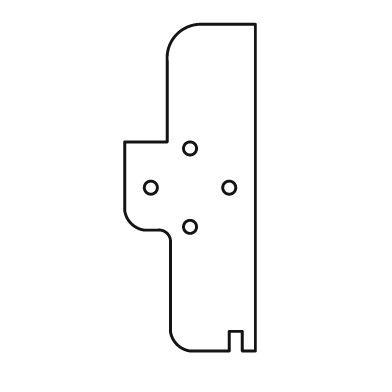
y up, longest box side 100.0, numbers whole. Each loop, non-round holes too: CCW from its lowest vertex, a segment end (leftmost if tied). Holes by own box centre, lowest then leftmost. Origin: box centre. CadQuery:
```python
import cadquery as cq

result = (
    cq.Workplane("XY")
    .moveTo(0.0, -50.0)
    .lineTo(12.0, -50.0)
    .lineTo(12.0, -44.0)
    .lineTo(16.0, -44.0)
    .lineTo(16.0, -50.0)
    .lineTo(20.0, -50.0)
    .lineTo(20.0, 50.0)
    .lineTo(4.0, 50.0)
    .threePointArc((-4.0, 47.0), (-7.0, 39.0))
    .lineTo(-7.0, 14.0)
    .lineTo(-20.0, 14.0)
    .lineTo(-20.0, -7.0)
    .threePointArc((-18.0, -11.0), (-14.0, -13.0))
    .lineTo(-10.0, -13.0)
    .threePointArc((-7.0, -14.0), (-6.0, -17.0))
    .lineTo(-6.0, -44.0)
    .threePointArc((-4.0, -48.0), (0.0, -50.0))
    .close()
    .moveTo(0.0, -12.0)
    .circle(2.0)
    .moveTo(-12.0, 0.0)
    .circle(2.0)
    .moveTo(12.0, 0.0)
    .circle(2.0)
    .moveTo(0.0, 12.0)
    .circle(2.0)
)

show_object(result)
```